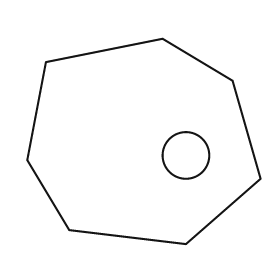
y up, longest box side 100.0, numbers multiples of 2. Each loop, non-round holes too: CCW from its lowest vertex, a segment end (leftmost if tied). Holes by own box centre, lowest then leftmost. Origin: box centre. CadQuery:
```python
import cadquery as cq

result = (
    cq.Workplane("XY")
    .moveTo(18.0, -44.0)
    .lineTo(50.0, -16.0)
    .lineTo(38.0, 26.0)
    .lineTo(8.0, 44.0)
    .lineTo(-42.0, 34.0)
    .lineTo(-50.0, -8.0)
    .lineTo(-32.0, -38.0)
    .close()
    .moveTo(18.0, -6.0)
    .circle(10.0)
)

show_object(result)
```